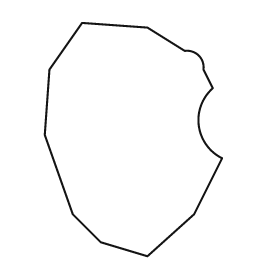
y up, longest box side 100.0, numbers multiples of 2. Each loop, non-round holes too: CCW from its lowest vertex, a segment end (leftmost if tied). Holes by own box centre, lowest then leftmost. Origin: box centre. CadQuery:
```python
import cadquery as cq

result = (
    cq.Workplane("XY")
    .moveTo(6.0, -50.0)
    .lineTo(26.0, -32.0)
    .lineTo(38.0, -8.0)
    .threePointArc((28.0, 6.0), (34.0, 22.0))
    .lineTo(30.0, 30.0)
    .threePointArc((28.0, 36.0), (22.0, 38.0))
    .lineTo(6.0, 48.0)
    .lineTo(-22.0, 50.0)
    .lineTo(-36.0, 30.0)
    .lineTo(-38.0, 2.0)
    .lineTo(-26.0, -32.0)
    .lineTo(-14.0, -44.0)
    .close()
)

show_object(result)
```